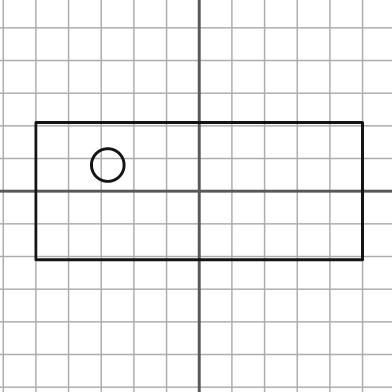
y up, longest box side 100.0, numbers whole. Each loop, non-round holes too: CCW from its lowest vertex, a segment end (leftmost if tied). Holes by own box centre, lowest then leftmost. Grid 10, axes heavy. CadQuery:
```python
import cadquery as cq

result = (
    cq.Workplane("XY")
    .moveTo(-50.0, -21.0)
    .lineTo(50.0, -21.0)
    .lineTo(50.0, 21.0)
    .lineTo(-50.0, 21.0)
    .close()
    .moveTo(-28.0, 8.0)
    .circle(5.0)
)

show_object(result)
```